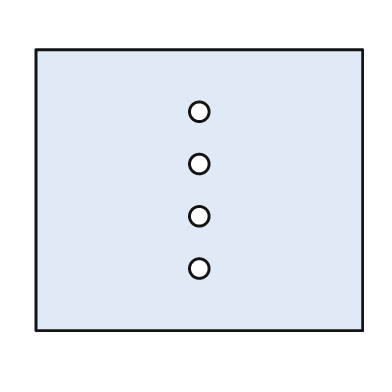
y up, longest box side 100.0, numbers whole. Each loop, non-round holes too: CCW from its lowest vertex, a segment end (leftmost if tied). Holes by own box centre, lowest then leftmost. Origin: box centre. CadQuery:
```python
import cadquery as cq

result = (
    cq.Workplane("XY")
    .moveTo(-50.0, -43.0)
    .lineTo(50.0, -43.0)
    .lineTo(50.0, 43.0)
    .lineTo(-50.0, 43.0)
    .close()
    .moveTo(0.0, -24.0)
    .circle(3.0)
    .moveTo(0.0, -8.0)
    .circle(3.0)
    .moveTo(0.0, 8.0)
    .circle(3.0)
    .moveTo(0.0, 24.0)
    .circle(3.0)
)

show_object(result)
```